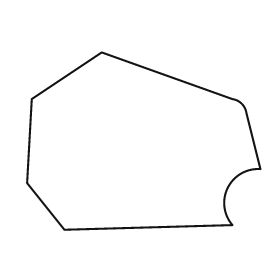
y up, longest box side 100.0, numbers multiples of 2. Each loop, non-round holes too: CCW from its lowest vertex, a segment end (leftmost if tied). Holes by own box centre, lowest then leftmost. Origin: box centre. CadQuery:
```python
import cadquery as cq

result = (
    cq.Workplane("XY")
    .moveTo(-34.0, -38.0)
    .lineTo(38.0, -36.0)
    .threePointArc((36.0, -20.0), (50.0, -12.0))
    .lineTo(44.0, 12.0)
    .threePointArc((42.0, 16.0), (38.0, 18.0))
    .lineTo(-18.0, 38.0)
    .lineTo(-48.0, 18.0)
    .lineTo(-50.0, -18.0)
    .close()
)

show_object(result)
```